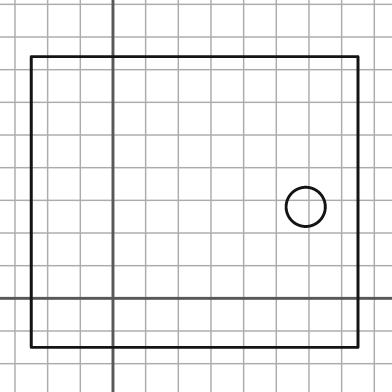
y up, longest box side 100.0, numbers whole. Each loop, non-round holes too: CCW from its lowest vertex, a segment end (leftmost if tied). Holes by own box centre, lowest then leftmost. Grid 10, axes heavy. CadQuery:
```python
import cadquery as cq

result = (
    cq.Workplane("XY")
    .moveTo(-25.0, -15.0)
    .lineTo(75.0, -15.0)
    .lineTo(75.0, 74.0)
    .lineTo(-25.0, 74.0)
    .close()
    .moveTo(59.0, 28.0)
    .circle(6.0)
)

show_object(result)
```